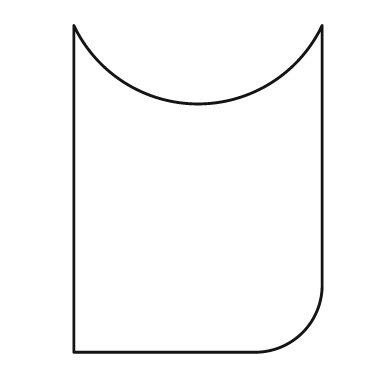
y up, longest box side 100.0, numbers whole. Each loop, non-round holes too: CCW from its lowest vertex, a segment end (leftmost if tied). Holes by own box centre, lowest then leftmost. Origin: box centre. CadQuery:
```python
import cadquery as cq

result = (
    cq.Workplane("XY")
    .moveTo(-38.0, -50.0)
    .lineTo(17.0, -50.0)
    .threePointArc((32.0, -44.0), (38.0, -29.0))
    .lineTo(38.0, 50.0)
    .threePointArc((0.0, 26.0), (-38.0, 50.0))
    .close()
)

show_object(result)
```